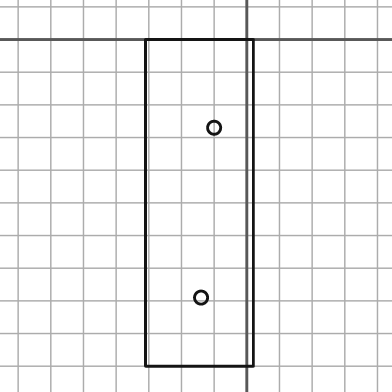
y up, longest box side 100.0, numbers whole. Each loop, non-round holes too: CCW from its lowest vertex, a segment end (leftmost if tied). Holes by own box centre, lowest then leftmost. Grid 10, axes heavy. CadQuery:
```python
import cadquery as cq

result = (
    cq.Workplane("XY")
    .moveTo(-31.0, -100.0)
    .lineTo(2.0, -100.0)
    .lineTo(2.0, 0.0)
    .lineTo(-31.0, 0.0)
    .close()
    .moveTo(-14.0, -79.0)
    .circle(2.0)
    .moveTo(-10.0, -27.0)
    .circle(2.0)
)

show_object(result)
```